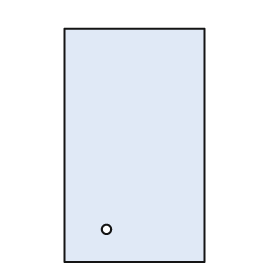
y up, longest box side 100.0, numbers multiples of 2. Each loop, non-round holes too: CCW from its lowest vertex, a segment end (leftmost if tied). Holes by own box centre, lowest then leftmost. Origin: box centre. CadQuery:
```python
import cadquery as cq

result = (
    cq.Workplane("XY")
    .moveTo(-30.0, -50.0)
    .lineTo(30.0, -50.0)
    .lineTo(30.0, 50.0)
    .lineTo(-30.0, 50.0)
    .close()
    .moveTo(-12.0, -36.0)
    .circle(2.0)
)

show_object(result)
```